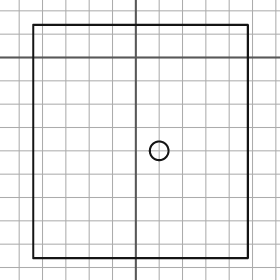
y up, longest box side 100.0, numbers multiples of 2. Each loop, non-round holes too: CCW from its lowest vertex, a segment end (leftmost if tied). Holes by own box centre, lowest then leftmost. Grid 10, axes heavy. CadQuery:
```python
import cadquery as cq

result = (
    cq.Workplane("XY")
    .moveTo(-44.0, -86.0)
    .lineTo(48.0, -86.0)
    .lineTo(48.0, 14.0)
    .lineTo(-44.0, 14.0)
    .close()
    .moveTo(10.0, -40.0)
    .circle(4.0)
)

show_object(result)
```